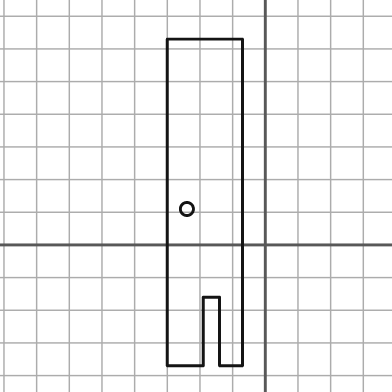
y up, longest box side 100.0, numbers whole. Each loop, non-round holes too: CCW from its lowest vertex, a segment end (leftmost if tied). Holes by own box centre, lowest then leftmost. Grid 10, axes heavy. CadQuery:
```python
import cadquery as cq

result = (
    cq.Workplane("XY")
    .moveTo(-30.0, -37.0)
    .lineTo(-19.0, -37.0)
    .lineTo(-19.0, -16.0)
    .lineTo(-14.0, -16.0)
    .lineTo(-14.0, -37.0)
    .lineTo(-7.0, -37.0)
    .lineTo(-7.0, 63.0)
    .lineTo(-30.0, 63.0)
    .close()
    .moveTo(-24.0, 11.0)
    .circle(2.0)
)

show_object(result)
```